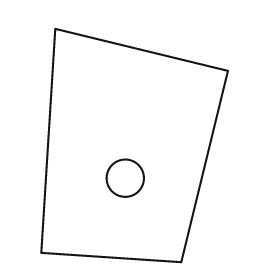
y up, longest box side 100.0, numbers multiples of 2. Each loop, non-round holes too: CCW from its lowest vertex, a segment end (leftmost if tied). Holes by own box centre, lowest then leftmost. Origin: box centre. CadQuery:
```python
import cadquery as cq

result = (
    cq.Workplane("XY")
    .moveTo(20.0, -50.0)
    .lineTo(40.0, 32.0)
    .lineTo(-34.0, 50.0)
    .lineTo(-40.0, -46.0)
    .close()
    .moveTo(-4.0, -14.0)
    .circle(8.0)
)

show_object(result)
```